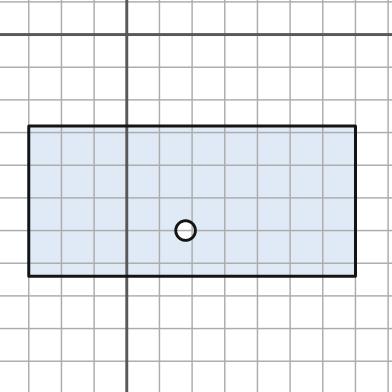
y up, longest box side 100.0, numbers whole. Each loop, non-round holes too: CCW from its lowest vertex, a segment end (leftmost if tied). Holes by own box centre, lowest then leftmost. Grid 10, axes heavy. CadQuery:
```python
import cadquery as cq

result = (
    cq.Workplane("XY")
    .moveTo(-30.0, -74.0)
    .lineTo(70.0, -74.0)
    .lineTo(70.0, -28.0)
    .lineTo(-30.0, -28.0)
    .close()
    .moveTo(18.0, -60.0)
    .circle(3.0)
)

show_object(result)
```